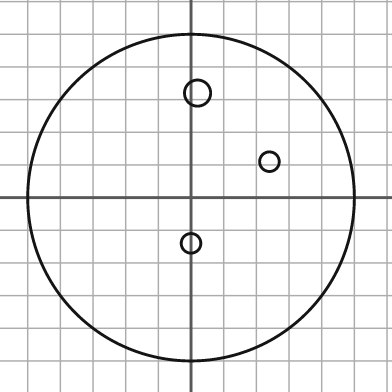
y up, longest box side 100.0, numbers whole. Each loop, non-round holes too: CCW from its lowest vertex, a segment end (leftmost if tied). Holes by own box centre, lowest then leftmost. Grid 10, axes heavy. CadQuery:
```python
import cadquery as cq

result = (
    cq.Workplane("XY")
    .moveTo(0.0, 0.0)
    .circle(50.0)
    .moveTo(0.0, -14.0)
    .circle(3.0)
    .moveTo(24.0, 11.0)
    .circle(3.0)
    .moveTo(2.0, 32.0)
    .circle(4.0)
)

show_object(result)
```